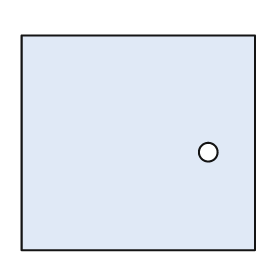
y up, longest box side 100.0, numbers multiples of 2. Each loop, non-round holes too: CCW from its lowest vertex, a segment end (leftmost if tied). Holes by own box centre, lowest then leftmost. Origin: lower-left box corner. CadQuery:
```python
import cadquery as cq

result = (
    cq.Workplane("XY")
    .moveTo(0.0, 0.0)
    .lineTo(100.0, 0.0)
    .lineTo(100.0, 92.0)
    .lineTo(0.0, 92.0)
    .close()
    .moveTo(80.0, 42.0)
    .circle(4.0)
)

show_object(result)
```